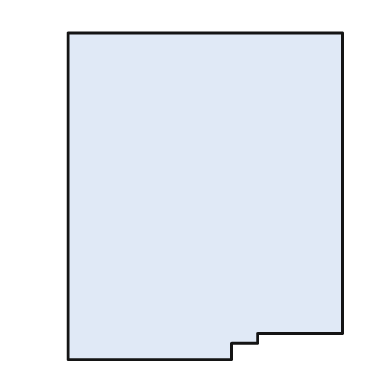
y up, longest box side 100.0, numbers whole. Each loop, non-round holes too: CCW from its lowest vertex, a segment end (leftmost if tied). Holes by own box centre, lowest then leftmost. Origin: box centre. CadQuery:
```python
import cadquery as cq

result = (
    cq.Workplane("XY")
    .moveTo(-42.0, -50.0)
    .lineTo(8.0, -50.0)
    .lineTo(8.0, -45.0)
    .lineTo(16.0, -45.0)
    .lineTo(16.0, -42.0)
    .lineTo(42.0, -42.0)
    .lineTo(42.0, 50.0)
    .lineTo(-42.0, 50.0)
    .close()
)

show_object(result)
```